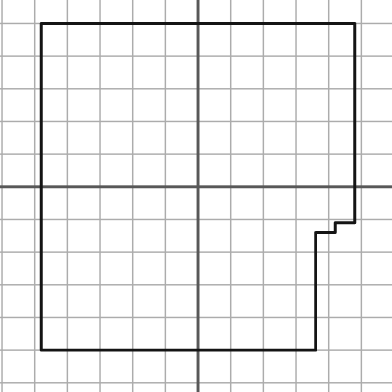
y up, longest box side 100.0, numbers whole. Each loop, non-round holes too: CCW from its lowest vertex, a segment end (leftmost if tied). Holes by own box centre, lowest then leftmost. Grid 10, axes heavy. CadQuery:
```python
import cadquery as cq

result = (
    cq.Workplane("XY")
    .moveTo(-48.0, -50.0)
    .lineTo(36.0, -50.0)
    .lineTo(36.0, -14.0)
    .lineTo(42.0, -14.0)
    .lineTo(42.0, -11.0)
    .lineTo(48.0, -11.0)
    .lineTo(48.0, 50.0)
    .lineTo(-48.0, 50.0)
    .close()
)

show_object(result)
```